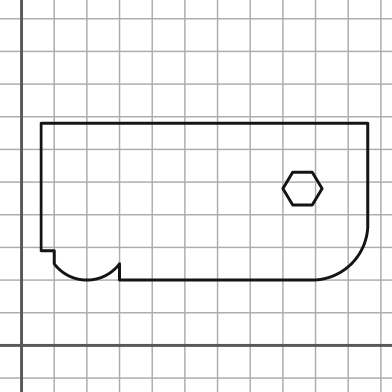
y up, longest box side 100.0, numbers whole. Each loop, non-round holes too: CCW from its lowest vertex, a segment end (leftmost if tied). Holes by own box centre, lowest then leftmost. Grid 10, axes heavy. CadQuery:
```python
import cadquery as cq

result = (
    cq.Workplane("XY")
    .moveTo(30.0, 20.0)
    .lineTo(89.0, 20.0)
    .threePointArc((101.0, 25.0), (106.0, 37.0))
    .lineTo(106.0, 68.0)
    .lineTo(6.0, 68.0)
    .lineTo(6.0, 29.0)
    .lineTo(10.0, 29.0)
    .lineTo(10.0, 25.0)
    .threePointArc((20.0, 20.0), (30.0, 25.0))
    .close()
    .moveTo(83.0, 43.0)
    .lineTo(89.0, 43.0)
    .lineTo(92.0, 48.0)
    .lineTo(89.0, 53.0)
    .lineTo(83.0, 53.0)
    .lineTo(80.0, 48.0)
    .close()
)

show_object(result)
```